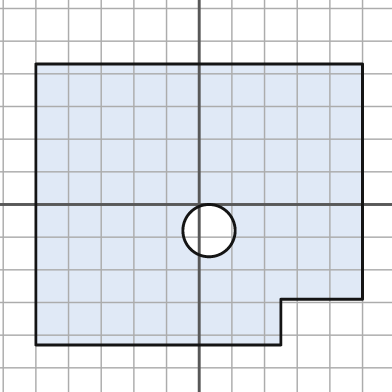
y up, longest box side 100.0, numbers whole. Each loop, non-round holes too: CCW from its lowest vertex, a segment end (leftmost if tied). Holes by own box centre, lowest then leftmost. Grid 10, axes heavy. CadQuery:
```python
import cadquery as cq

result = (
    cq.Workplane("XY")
    .moveTo(-50.0, -43.0)
    .lineTo(25.0, -43.0)
    .lineTo(25.0, -29.0)
    .lineTo(50.0, -29.0)
    .lineTo(50.0, 43.0)
    .lineTo(-50.0, 43.0)
    .close()
    .moveTo(3.0, -8.0)
    .circle(8.0)
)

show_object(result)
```